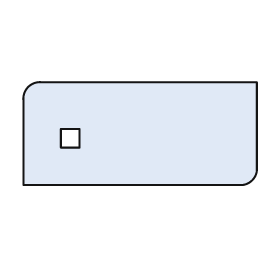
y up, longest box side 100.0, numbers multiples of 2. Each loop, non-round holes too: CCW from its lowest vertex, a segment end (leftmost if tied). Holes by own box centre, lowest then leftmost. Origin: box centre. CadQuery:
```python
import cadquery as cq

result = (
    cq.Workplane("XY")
    .moveTo(-50.0, -22.0)
    .lineTo(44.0, -22.0)
    .threePointArc((48.0, -20.0), (50.0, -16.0))
    .lineTo(50.0, 22.0)
    .lineTo(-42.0, 22.0)
    .threePointArc((-48.0, 20.0), (-50.0, 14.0))
    .close()
    .moveTo(-34.0, -6.0)
    .lineTo(-26.0, -6.0)
    .lineTo(-26.0, 2.0)
    .lineTo(-34.0, 2.0)
    .close()
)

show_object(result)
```